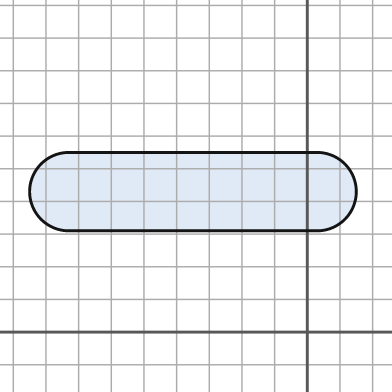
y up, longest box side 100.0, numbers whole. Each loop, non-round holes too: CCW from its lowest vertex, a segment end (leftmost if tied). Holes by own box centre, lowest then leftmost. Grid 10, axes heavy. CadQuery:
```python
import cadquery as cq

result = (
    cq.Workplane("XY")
    .moveTo(-73.0, 31.0)
    .lineTo(3.0, 31.0)
    .threePointArc((15.0, 43.0), (3.0, 55.0))
    .lineTo(-73.0, 55.0)
    .threePointArc((-85.0, 43.0), (-73.0, 31.0))
    .close()
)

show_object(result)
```